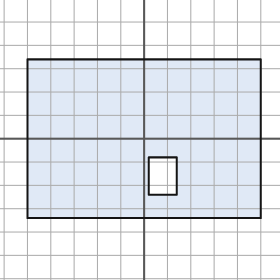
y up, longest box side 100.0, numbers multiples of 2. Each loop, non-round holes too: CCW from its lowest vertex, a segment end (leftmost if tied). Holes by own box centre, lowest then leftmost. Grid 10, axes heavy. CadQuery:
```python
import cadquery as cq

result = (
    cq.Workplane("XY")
    .moveTo(-50.0, -34.0)
    .lineTo(50.0, -34.0)
    .lineTo(50.0, 34.0)
    .lineTo(-50.0, 34.0)
    .close()
    .moveTo(2.0, -24.0)
    .lineTo(14.0, -24.0)
    .lineTo(14.0, -8.0)
    .lineTo(2.0, -8.0)
    .close()
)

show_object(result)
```